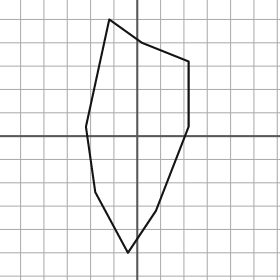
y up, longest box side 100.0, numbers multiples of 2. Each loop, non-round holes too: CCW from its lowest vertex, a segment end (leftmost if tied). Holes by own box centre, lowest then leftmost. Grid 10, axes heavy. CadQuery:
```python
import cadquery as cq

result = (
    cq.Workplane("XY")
    .moveTo(-4.0, -50.0)
    .lineTo(8.0, -32.0)
    .lineTo(22.0, 4.0)
    .lineTo(22.0, 32.0)
    .lineTo(2.0, 40.0)
    .lineTo(-12.0, 50.0)
    .lineTo(-22.0, 4.0)
    .lineTo(-18.0, -24.0)
    .close()
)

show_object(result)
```